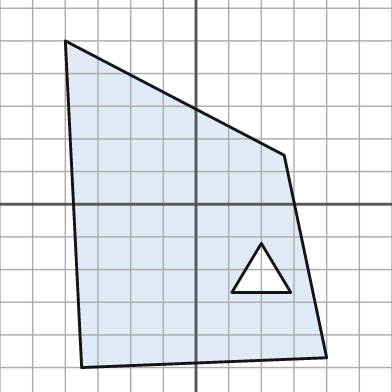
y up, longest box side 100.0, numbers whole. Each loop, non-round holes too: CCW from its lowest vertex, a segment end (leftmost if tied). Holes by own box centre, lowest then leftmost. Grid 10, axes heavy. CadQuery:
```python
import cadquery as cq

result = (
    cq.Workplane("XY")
    .moveTo(-35.0, -50.0)
    .lineTo(40.0, -47.0)
    .lineTo(27.0, 15.0)
    .lineTo(-40.0, 50.0)
    .close()
    .moveTo(11.0, -27.0)
    .lineTo(29.0, -27.0)
    .lineTo(20.0, -12.0)
    .close()
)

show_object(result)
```